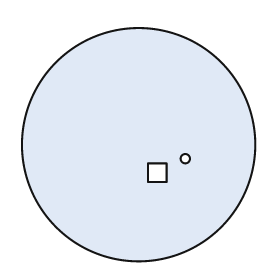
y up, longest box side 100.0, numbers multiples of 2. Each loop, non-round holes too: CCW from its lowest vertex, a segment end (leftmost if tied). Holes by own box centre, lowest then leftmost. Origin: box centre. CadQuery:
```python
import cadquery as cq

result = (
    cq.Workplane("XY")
    .moveTo(0.0, 0.0)
    .circle(50.0)
    .moveTo(4.0, -16.0)
    .lineTo(12.0, -16.0)
    .lineTo(12.0, -8.0)
    .lineTo(4.0, -8.0)
    .close()
    .moveTo(20.0, -6.0)
    .circle(2.0)
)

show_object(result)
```